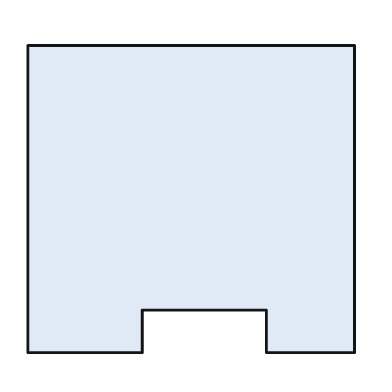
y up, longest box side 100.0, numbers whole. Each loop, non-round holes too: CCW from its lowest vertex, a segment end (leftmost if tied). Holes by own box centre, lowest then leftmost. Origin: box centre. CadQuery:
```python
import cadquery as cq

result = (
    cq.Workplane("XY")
    .moveTo(-50.0, -47.0)
    .lineTo(-15.0, -47.0)
    .lineTo(-15.0, -34.0)
    .lineTo(23.0, -34.0)
    .lineTo(23.0, -47.0)
    .lineTo(50.0, -47.0)
    .lineTo(50.0, 47.0)
    .lineTo(-50.0, 47.0)
    .close()
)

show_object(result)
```